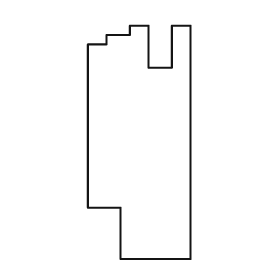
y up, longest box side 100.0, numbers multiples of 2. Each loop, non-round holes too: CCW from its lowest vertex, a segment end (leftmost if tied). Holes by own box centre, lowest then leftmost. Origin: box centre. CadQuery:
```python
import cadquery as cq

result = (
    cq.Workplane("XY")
    .moveTo(-8.0, -50.0)
    .lineTo(22.0, -50.0)
    .lineTo(22.0, 50.0)
    .lineTo(14.0, 50.0)
    .lineTo(14.0, 32.0)
    .lineTo(4.0, 32.0)
    .lineTo(4.0, 50.0)
    .lineTo(-4.0, 50.0)
    .lineTo(-4.0, 46.0)
    .lineTo(-14.0, 46.0)
    .lineTo(-14.0, 42.0)
    .lineTo(-22.0, 42.0)
    .lineTo(-22.0, -28.0)
    .lineTo(-8.0, -28.0)
    .close()
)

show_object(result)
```